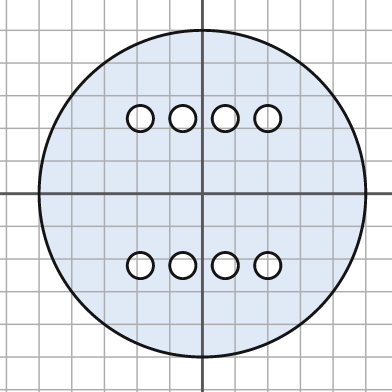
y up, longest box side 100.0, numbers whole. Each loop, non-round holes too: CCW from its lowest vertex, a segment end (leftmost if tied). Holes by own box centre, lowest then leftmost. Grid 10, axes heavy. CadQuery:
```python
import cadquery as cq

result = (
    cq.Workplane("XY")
    .moveTo(0.0, 0.0)
    .circle(50.0)
    .moveTo(-19.0, -22.0)
    .circle(4.0)
    .moveTo(-6.0, -22.0)
    .circle(4.0)
    .moveTo(7.0, -22.0)
    .circle(4.0)
    .moveTo(20.0, -22.0)
    .circle(4.0)
    .moveTo(-19.0, 23.0)
    .circle(4.0)
    .moveTo(-6.0, 23.0)
    .circle(4.0)
    .moveTo(7.0, 23.0)
    .circle(4.0)
    .moveTo(20.0, 23.0)
    .circle(4.0)
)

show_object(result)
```